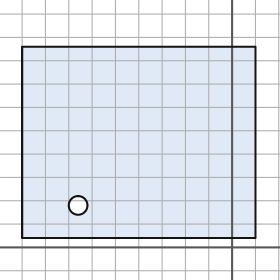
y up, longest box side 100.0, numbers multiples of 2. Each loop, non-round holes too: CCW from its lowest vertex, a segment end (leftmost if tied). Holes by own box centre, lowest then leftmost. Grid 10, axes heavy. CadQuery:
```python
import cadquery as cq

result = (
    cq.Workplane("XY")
    .moveTo(-90.0, 4.0)
    .lineTo(10.0, 4.0)
    .lineTo(10.0, 86.0)
    .lineTo(-90.0, 86.0)
    .close()
    .moveTo(-66.0, 18.0)
    .circle(4.0)
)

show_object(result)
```